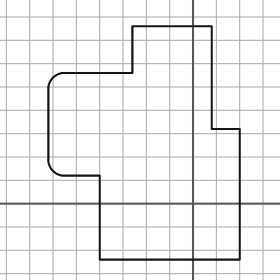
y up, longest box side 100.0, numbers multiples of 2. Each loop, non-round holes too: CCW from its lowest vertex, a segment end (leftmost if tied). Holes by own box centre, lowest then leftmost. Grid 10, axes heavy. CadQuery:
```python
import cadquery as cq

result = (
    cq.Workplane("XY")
    .moveTo(-40.0, -24.0)
    .lineTo(20.0, -24.0)
    .lineTo(20.0, 32.0)
    .lineTo(8.0, 32.0)
    .lineTo(8.0, 76.0)
    .lineTo(-26.0, 76.0)
    .lineTo(-26.0, 56.0)
    .lineTo(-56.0, 56.0)
    .threePointArc((-60.0, 54.0), (-62.0, 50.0))
    .lineTo(-62.0, 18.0)
    .threePointArc((-60.0, 14.0), (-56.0, 12.0))
    .lineTo(-40.0, 12.0)
    .close()
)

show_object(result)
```